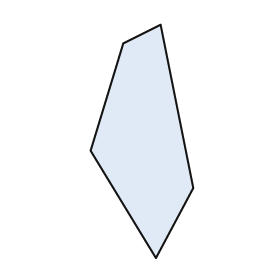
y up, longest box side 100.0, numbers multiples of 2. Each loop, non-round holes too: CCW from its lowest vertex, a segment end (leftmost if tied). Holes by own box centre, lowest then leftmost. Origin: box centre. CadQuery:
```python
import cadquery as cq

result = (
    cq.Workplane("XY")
    .moveTo(6.0, -50.0)
    .lineTo(22.0, -20.0)
    .lineTo(8.0, 50.0)
    .lineTo(-8.0, 42.0)
    .lineTo(-22.0, -4.0)
    .close()
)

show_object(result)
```